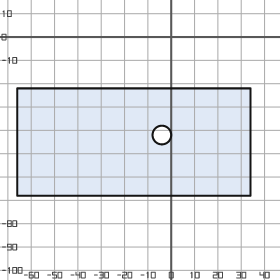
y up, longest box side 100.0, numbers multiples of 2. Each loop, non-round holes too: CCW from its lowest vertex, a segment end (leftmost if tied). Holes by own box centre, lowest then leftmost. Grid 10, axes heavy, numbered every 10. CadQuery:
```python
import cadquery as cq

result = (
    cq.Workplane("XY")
    .moveTo(-66.0, -68.0)
    .lineTo(34.0, -68.0)
    .lineTo(34.0, -22.0)
    .lineTo(-66.0, -22.0)
    .close()
    .moveTo(-4.0, -42.0)
    .circle(4.0)
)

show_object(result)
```